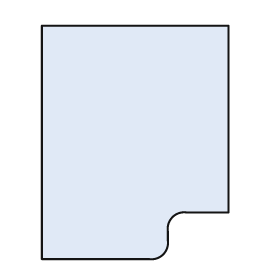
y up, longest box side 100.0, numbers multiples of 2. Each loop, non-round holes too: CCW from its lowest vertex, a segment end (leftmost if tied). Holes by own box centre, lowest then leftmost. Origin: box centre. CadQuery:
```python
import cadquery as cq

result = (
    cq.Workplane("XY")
    .moveTo(-40.0, -50.0)
    .lineTo(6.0, -50.0)
    .threePointArc((12.0, -48.0), (14.0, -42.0))
    .lineTo(14.0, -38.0)
    .threePointArc((16.0, -32.0), (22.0, -30.0))
    .lineTo(40.0, -30.0)
    .lineTo(40.0, 50.0)
    .lineTo(-40.0, 50.0)
    .close()
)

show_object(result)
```